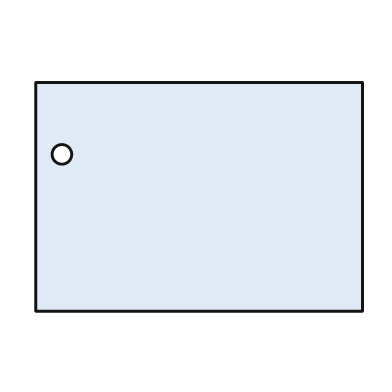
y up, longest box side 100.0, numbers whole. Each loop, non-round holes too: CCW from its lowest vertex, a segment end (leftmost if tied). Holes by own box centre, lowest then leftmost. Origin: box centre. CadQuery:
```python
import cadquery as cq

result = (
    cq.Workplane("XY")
    .moveTo(-50.0, -35.0)
    .lineTo(50.0, -35.0)
    .lineTo(50.0, 35.0)
    .lineTo(-50.0, 35.0)
    .close()
    .moveTo(-42.0, 13.0)
    .circle(3.0)
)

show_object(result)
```